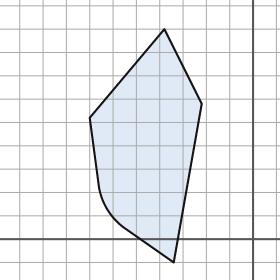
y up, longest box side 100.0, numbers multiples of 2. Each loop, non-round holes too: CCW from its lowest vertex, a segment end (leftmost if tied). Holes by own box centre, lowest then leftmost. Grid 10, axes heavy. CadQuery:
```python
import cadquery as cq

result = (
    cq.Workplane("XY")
    .moveTo(-34.0, -10.0)
    .lineTo(-22.0, 58.0)
    .lineTo(-38.0, 90.0)
    .lineTo(-70.0, 52.0)
    .lineTo(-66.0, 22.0)
    .threePointArc((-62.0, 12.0), (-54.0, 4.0))
    .close()
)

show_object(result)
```